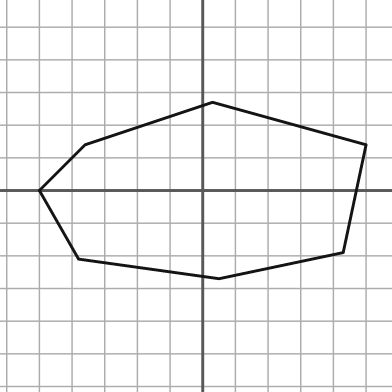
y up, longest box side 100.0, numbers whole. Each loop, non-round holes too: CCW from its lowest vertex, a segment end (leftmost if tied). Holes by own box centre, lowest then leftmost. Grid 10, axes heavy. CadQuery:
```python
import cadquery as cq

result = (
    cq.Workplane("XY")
    .moveTo(5.0, -27.0)
    .lineTo(43.0, -19.0)
    .lineTo(50.0, 14.0)
    .lineTo(3.0, 27.0)
    .lineTo(-36.0, 14.0)
    .lineTo(-50.0, 0.0)
    .lineTo(-38.0, -21.0)
    .close()
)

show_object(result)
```